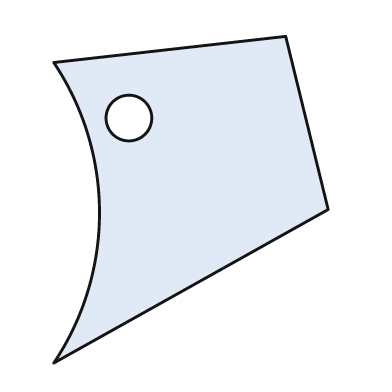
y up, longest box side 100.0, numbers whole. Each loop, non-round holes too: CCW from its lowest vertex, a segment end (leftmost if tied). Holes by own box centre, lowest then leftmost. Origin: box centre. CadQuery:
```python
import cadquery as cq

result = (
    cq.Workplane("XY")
    .moveTo(-42.0, -50.0)
    .lineTo(42.0, -3.0)
    .lineTo(29.0, 50.0)
    .lineTo(-42.0, 42.0)
    .threePointArc((-28.0, -4.0), (-42.0, -50.0))
    .close()
    .moveTo(-19.0, 25.0)
    .circle(7.0)
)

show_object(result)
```